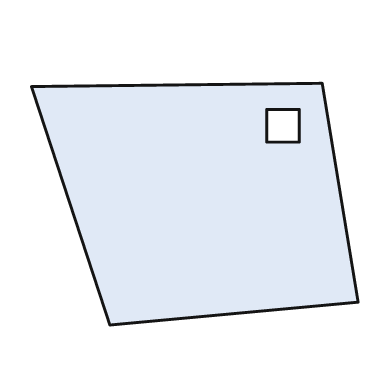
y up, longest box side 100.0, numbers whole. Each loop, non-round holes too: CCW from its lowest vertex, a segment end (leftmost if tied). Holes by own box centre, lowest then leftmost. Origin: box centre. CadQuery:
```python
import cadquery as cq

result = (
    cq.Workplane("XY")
    .moveTo(-26.0, -37.0)
    .lineTo(50.0, -30.0)
    .lineTo(39.0, 37.0)
    .lineTo(-50.0, 36.0)
    .close()
    .moveTo(22.0, 19.0)
    .lineTo(32.0, 19.0)
    .lineTo(32.0, 29.0)
    .lineTo(22.0, 29.0)
    .close()
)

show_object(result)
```